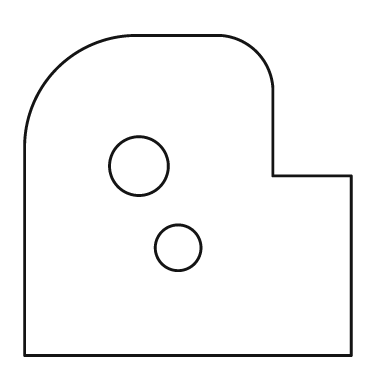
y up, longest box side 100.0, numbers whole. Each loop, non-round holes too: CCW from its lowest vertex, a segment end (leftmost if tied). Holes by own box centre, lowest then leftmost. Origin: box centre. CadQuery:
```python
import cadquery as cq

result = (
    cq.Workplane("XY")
    .moveTo(-50.0, -49.0)
    .lineTo(50.0, -49.0)
    .lineTo(50.0, 6.0)
    .lineTo(26.0, 6.0)
    .lineTo(26.0, 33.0)
    .threePointArc((21.0, 44.0), (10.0, 49.0))
    .lineTo(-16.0, 49.0)
    .threePointArc((-40.0, 39.0), (-50.0, 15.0))
    .close()
    .moveTo(-3.0, -16.0)
    .circle(7.0)
    .moveTo(-15.0, 9.0)
    .circle(9.0)
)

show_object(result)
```